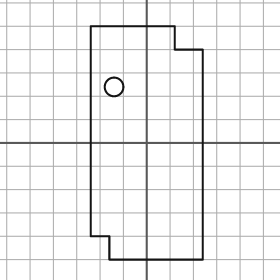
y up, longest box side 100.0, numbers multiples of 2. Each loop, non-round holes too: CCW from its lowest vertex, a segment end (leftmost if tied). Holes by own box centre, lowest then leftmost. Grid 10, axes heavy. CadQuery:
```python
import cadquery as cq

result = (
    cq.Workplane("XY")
    .moveTo(-16.0, -50.0)
    .lineTo(24.0, -50.0)
    .lineTo(24.0, 40.0)
    .lineTo(12.0, 40.0)
    .lineTo(12.0, 50.0)
    .lineTo(-24.0, 50.0)
    .lineTo(-24.0, -40.0)
    .lineTo(-16.0, -40.0)
    .close()
    .moveTo(-14.0, 24.0)
    .circle(4.0)
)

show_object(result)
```